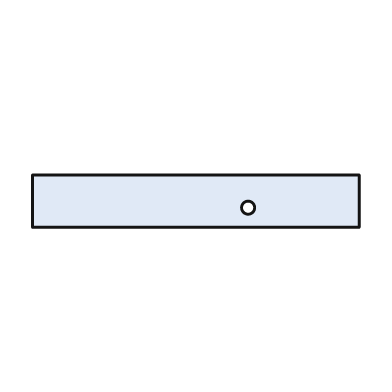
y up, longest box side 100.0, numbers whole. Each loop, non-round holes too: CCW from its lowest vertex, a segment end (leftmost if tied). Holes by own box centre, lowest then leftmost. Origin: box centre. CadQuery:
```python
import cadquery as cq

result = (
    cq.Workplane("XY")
    .moveTo(-50.0, -8.0)
    .lineTo(50.0, -8.0)
    .lineTo(50.0, 8.0)
    .lineTo(-50.0, 8.0)
    .close()
    .moveTo(16.0, -2.0)
    .circle(2.0)
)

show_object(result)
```